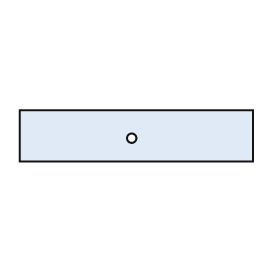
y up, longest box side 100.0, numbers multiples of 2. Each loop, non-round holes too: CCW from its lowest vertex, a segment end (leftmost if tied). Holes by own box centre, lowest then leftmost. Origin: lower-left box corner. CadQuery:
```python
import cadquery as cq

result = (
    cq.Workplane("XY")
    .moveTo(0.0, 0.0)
    .lineTo(100.0, 0.0)
    .lineTo(100.0, 22.0)
    .lineTo(0.0, 22.0)
    .close()
    .moveTo(48.0, 10.0)
    .circle(2.0)
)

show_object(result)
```